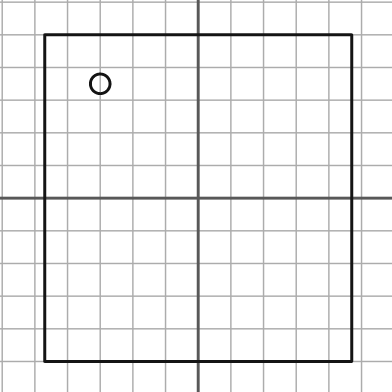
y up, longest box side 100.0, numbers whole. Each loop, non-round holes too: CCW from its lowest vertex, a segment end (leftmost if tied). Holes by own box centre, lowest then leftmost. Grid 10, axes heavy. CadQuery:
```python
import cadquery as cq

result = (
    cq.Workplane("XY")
    .moveTo(-47.0, -50.0)
    .lineTo(47.0, -50.0)
    .lineTo(47.0, 50.0)
    .lineTo(-47.0, 50.0)
    .close()
    .moveTo(-30.0, 35.0)
    .circle(3.0)
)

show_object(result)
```